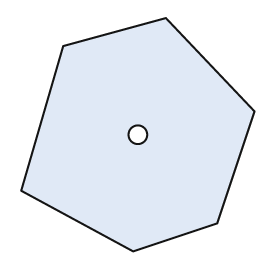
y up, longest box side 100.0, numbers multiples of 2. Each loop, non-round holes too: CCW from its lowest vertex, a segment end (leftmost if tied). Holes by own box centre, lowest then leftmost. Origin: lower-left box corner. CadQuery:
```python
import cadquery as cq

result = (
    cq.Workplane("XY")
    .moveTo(48.0, 0.0)
    .lineTo(84.0, 12.0)
    .lineTo(100.0, 60.0)
    .lineTo(62.0, 100.0)
    .lineTo(18.0, 88.0)
    .lineTo(0.0, 26.0)
    .close()
    .moveTo(50.0, 50.0)
    .circle(4.0)
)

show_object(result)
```